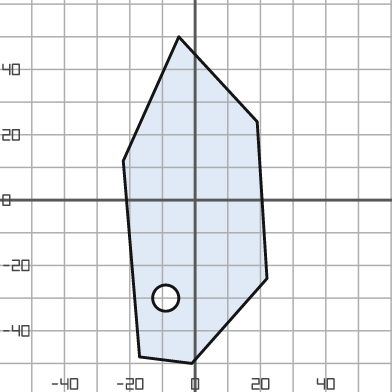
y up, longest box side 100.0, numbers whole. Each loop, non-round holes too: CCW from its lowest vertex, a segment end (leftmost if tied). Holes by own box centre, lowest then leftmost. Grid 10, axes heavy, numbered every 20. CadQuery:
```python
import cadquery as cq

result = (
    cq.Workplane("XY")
    .moveTo(-1.0, -50.0)
    .lineTo(22.0, -24.0)
    .lineTo(19.0, 24.0)
    .lineTo(-5.0, 50.0)
    .lineTo(-22.0, 12.0)
    .lineTo(-17.0, -48.0)
    .close()
    .moveTo(-9.0, -30.0)
    .circle(4.0)
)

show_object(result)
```